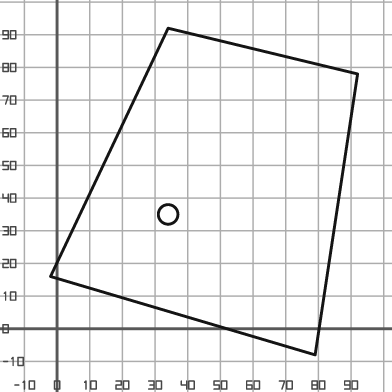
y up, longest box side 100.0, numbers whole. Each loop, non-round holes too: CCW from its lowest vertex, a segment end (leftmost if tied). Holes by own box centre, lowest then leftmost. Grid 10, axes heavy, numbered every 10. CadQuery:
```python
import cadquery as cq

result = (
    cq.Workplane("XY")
    .moveTo(79.0, -8.0)
    .lineTo(92.0, 78.0)
    .lineTo(34.0, 92.0)
    .lineTo(-2.0, 16.0)
    .close()
    .moveTo(34.0, 35.0)
    .circle(3.0)
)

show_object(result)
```